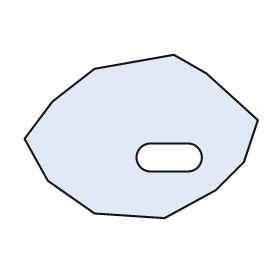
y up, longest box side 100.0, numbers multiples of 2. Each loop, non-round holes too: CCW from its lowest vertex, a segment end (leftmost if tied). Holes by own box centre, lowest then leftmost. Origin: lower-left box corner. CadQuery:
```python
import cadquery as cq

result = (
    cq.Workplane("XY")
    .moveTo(60.0, 0.0)
    .lineTo(82.0, 12.0)
    .lineTo(94.0, 24.0)
    .lineTo(100.0, 42.0)
    .lineTo(78.0, 62.0)
    .lineTo(64.0, 70.0)
    .lineTo(30.0, 64.0)
    .lineTo(12.0, 50.0)
    .lineTo(0.0, 34.0)
    .lineTo(10.0, 16.0)
    .lineTo(30.0, 2.0)
    .close()
    .moveTo(54.0, 20.0)
    .lineTo(70.0, 20.0)
    .threePointArc((76.0, 26.0), (70.0, 32.0))
    .lineTo(54.0, 32.0)
    .threePointArc((48.0, 26.0), (54.0, 20.0))
    .close()
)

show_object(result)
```